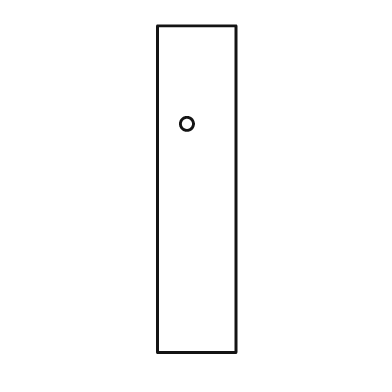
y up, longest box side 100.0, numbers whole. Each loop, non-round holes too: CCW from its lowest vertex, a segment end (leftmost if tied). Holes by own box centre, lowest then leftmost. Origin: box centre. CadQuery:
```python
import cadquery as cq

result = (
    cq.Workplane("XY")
    .moveTo(-12.0, -50.0)
    .lineTo(12.0, -50.0)
    .lineTo(12.0, 50.0)
    .lineTo(-12.0, 50.0)
    .close()
    .moveTo(-3.0, 20.0)
    .circle(2.0)
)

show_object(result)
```